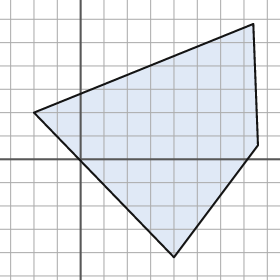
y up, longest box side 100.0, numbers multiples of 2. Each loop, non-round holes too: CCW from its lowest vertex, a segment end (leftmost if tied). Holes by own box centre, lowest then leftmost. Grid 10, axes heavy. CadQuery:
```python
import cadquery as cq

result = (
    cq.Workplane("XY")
    .moveTo(40.0, -42.0)
    .lineTo(76.0, 6.0)
    .lineTo(74.0, 58.0)
    .lineTo(-20.0, 20.0)
    .close()
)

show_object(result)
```